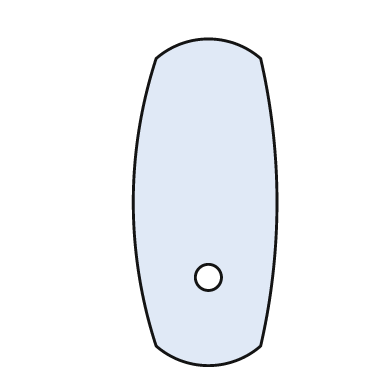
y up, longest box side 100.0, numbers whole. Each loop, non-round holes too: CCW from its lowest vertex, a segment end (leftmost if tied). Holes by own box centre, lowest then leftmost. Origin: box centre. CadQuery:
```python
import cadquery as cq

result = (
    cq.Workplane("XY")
    .moveTo(-15.0, -44.0)
    .threePointArc((1.0, -50.0), (17.0, -44.0))
    .threePointArc((22.0, 0.0), (17.0, 44.0))
    .threePointArc((1.0, 50.0), (-15.0, 44.0))
    .threePointArc((-22.0, 0.0), (-15.0, -44.0))
    .close()
    .moveTo(1.0, -23.0)
    .circle(4.0)
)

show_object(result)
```